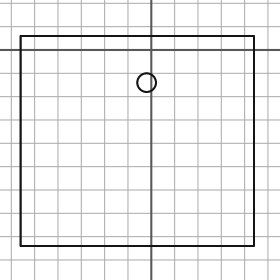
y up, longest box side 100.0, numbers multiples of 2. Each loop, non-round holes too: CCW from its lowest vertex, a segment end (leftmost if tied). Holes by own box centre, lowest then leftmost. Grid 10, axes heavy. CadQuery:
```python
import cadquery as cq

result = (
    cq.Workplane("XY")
    .moveTo(-56.0, -84.0)
    .lineTo(44.0, -84.0)
    .lineTo(44.0, 6.0)
    .lineTo(-56.0, 6.0)
    .close()
    .moveTo(-2.0, -14.0)
    .circle(4.0)
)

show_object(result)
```